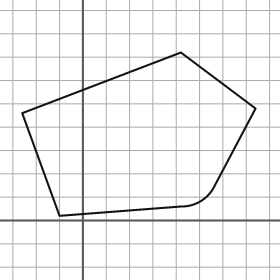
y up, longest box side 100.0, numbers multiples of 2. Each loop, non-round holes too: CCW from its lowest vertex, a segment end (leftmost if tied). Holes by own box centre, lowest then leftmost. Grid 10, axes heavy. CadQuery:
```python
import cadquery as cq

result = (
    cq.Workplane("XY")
    .moveTo(-10.0, 2.0)
    .lineTo(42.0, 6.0)
    .threePointArc((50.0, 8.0), (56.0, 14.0))
    .lineTo(74.0, 48.0)
    .lineTo(42.0, 72.0)
    .lineTo(-26.0, 46.0)
    .close()
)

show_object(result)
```